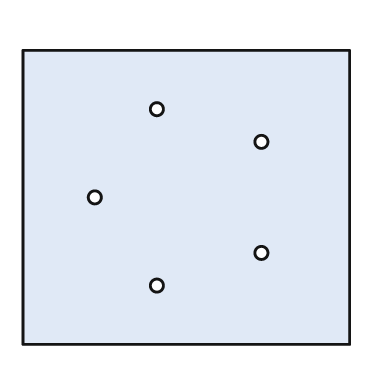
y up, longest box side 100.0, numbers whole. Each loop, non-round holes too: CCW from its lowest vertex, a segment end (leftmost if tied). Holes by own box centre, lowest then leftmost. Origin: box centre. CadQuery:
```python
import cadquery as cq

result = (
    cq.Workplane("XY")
    .moveTo(-50.0, -45.0)
    .lineTo(50.0, -45.0)
    .lineTo(50.0, 45.0)
    .lineTo(-50.0, 45.0)
    .close()
    .moveTo(-9.0, -27.0)
    .circle(2.0)
    .moveTo(23.0, -17.0)
    .circle(2.0)
    .moveTo(-28.0, 0.0)
    .circle(2.0)
    .moveTo(23.0, 17.0)
    .circle(2.0)
    .moveTo(-9.0, 27.0)
    .circle(2.0)
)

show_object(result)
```